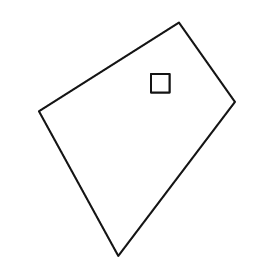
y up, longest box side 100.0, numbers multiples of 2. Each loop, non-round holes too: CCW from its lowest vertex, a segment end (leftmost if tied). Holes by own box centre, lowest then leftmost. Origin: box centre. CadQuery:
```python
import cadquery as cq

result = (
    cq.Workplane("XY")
    .moveTo(-8.0, -50.0)
    .lineTo(42.0, 16.0)
    .lineTo(18.0, 50.0)
    .lineTo(-42.0, 12.0)
    .close()
    .moveTo(6.0, 20.0)
    .lineTo(14.0, 20.0)
    .lineTo(14.0, 28.0)
    .lineTo(6.0, 28.0)
    .close()
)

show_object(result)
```